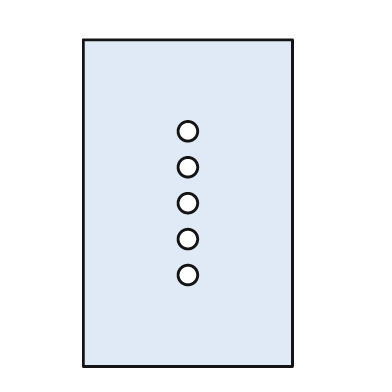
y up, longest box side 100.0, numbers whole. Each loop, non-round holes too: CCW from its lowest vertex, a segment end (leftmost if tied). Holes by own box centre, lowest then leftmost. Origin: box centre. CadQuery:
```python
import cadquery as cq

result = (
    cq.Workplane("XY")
    .moveTo(-32.0, -50.0)
    .lineTo(32.0, -50.0)
    .lineTo(32.0, 50.0)
    .lineTo(-32.0, 50.0)
    .close()
    .moveTo(0.0, -22.0)
    .circle(3.0)
    .moveTo(0.0, -11.0)
    .circle(3.0)
    .moveTo(0.0, 0.0)
    .circle(3.0)
    .moveTo(0.0, 11.0)
    .circle(3.0)
    .moveTo(0.0, 22.0)
    .circle(3.0)
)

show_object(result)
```